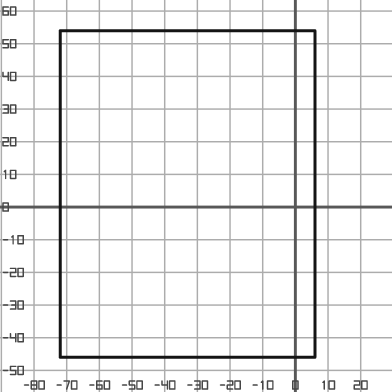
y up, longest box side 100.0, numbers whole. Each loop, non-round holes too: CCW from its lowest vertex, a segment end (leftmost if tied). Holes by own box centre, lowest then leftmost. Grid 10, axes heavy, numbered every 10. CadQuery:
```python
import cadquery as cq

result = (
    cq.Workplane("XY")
    .moveTo(-72.0, -46.0)
    .lineTo(6.0, -46.0)
    .lineTo(6.0, 54.0)
    .lineTo(-72.0, 54.0)
    .close()
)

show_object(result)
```